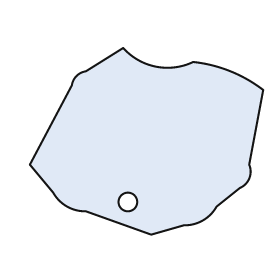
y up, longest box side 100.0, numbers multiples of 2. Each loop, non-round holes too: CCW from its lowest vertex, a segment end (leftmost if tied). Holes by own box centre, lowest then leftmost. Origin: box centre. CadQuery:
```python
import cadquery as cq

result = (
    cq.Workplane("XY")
    .moveTo(2.0, -40.0)
    .lineTo(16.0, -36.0)
    .threePointArc((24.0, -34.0), (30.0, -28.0))
    .lineTo(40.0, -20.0)
    .threePointArc((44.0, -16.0), (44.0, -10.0))
    .lineTo(50.0, 22.0)
    .threePointArc((36.0, 30.0), (20.0, 34.0))
    .threePointArc((4.0, 32.0), (-10.0, 40.0))
    .lineTo(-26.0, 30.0)
    .threePointArc((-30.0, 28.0), (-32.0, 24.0))
    .lineTo(-50.0, -10.0)
    .lineTo(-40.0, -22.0)
    .threePointArc((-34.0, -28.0), (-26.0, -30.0))
    .close()
    .moveTo(-8.0, -26.0)
    .circle(4.0)
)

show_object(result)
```